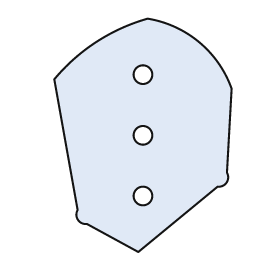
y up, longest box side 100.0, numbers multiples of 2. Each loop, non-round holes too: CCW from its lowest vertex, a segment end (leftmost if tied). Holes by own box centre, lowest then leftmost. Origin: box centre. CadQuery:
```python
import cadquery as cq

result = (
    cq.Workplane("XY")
    .moveTo(-2.0, -50.0)
    .lineTo(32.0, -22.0)
    .threePointArc((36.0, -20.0), (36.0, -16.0))
    .lineTo(38.0, 20.0)
    .threePointArc((24.0, 40.0), (2.0, 50.0))
    .threePointArc((-20.0, 40.0), (-38.0, 24.0))
    .lineTo(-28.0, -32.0)
    .threePointArc((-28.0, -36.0), (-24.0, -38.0))
    .close()
    .moveTo(0.0, -26.0)
    .circle(4.0)
    .moveTo(0.0, 0.0)
    .circle(4.0)
    .moveTo(0.0, 26.0)
    .circle(4.0)
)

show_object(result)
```